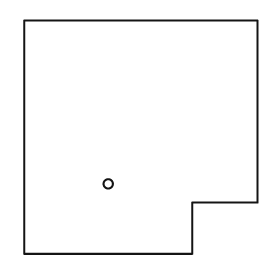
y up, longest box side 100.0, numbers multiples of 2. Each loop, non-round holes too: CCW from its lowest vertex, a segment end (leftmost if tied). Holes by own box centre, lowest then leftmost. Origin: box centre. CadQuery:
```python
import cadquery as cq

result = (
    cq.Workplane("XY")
    .moveTo(-50.0, -50.0)
    .lineTo(22.0, -50.0)
    .lineTo(22.0, -28.0)
    .lineTo(50.0, -28.0)
    .lineTo(50.0, 50.0)
    .lineTo(-50.0, 50.0)
    .close()
    .moveTo(-14.0, -20.0)
    .circle(2.0)
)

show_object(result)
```